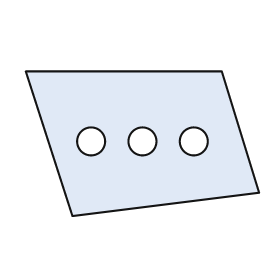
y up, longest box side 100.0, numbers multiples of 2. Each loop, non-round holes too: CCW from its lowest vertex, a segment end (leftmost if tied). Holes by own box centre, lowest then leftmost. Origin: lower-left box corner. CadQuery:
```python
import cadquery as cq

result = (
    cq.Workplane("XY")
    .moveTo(20.0, 0.0)
    .lineTo(100.0, 10.0)
    .lineTo(84.0, 62.0)
    .lineTo(0.0, 62.0)
    .close()
    .moveTo(28.0, 32.0)
    .circle(6.0)
    .moveTo(50.0, 32.0)
    .circle(6.0)
    .moveTo(72.0, 32.0)
    .circle(6.0)
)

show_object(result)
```